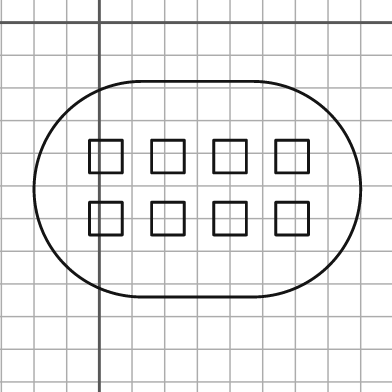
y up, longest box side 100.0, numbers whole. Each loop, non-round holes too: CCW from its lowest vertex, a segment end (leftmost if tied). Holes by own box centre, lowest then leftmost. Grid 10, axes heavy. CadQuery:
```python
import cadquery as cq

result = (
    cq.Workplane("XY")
    .moveTo(13.0, -84.0)
    .lineTo(47.0, -84.0)
    .threePointArc((80.0, -51.0), (47.0, -18.0))
    .lineTo(13.0, -18.0)
    .threePointArc((-20.0, -51.0), (13.0, -84.0))
    .close()
    .moveTo(-3.0, -65.0)
    .lineTo(7.0, -65.0)
    .lineTo(7.0, -55.0)
    .lineTo(-3.0, -55.0)
    .close()
    .moveTo(16.0, -65.0)
    .lineTo(26.0, -65.0)
    .lineTo(26.0, -55.0)
    .lineTo(16.0, -55.0)
    .close()
    .moveTo(35.0, -65.0)
    .lineTo(45.0, -65.0)
    .lineTo(45.0, -55.0)
    .lineTo(35.0, -55.0)
    .close()
    .moveTo(54.0, -65.0)
    .lineTo(64.0, -65.0)
    .lineTo(64.0, -55.0)
    .lineTo(54.0, -55.0)
    .close()
    .moveTo(-3.0, -46.0)
    .lineTo(7.0, -46.0)
    .lineTo(7.0, -36.0)
    .lineTo(-3.0, -36.0)
    .close()
    .moveTo(16.0, -46.0)
    .lineTo(26.0, -46.0)
    .lineTo(26.0, -36.0)
    .lineTo(16.0, -36.0)
    .close()
    .moveTo(35.0, -46.0)
    .lineTo(45.0, -46.0)
    .lineTo(45.0, -36.0)
    .lineTo(35.0, -36.0)
    .close()
    .moveTo(54.0, -46.0)
    .lineTo(64.0, -46.0)
    .lineTo(64.0, -36.0)
    .lineTo(54.0, -36.0)
    .close()
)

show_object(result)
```